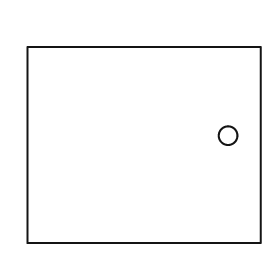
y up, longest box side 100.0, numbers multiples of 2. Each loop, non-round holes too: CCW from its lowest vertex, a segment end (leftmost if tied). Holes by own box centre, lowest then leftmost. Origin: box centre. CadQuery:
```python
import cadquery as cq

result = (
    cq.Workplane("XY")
    .moveTo(-50.0, -42.0)
    .lineTo(50.0, -42.0)
    .lineTo(50.0, 42.0)
    .lineTo(-50.0, 42.0)
    .close()
    .moveTo(36.0, 4.0)
    .circle(4.0)
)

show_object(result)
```